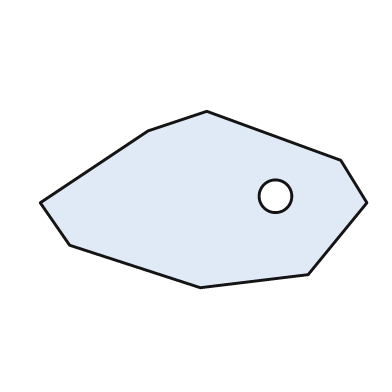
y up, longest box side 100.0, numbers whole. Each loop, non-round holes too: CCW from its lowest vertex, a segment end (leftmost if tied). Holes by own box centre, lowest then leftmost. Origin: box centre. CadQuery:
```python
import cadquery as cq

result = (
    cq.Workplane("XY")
    .moveTo(-1.0, -27.0)
    .lineTo(32.0, -23.0)
    .lineTo(50.0, -1.0)
    .lineTo(42.0, 12.0)
    .lineTo(1.0, 27.0)
    .lineTo(-17.0, 21.0)
    .lineTo(-50.0, -1.0)
    .lineTo(-41.0, -14.0)
    .close()
    .moveTo(22.0, 1.0)
    .circle(5.0)
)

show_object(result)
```